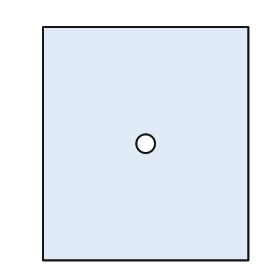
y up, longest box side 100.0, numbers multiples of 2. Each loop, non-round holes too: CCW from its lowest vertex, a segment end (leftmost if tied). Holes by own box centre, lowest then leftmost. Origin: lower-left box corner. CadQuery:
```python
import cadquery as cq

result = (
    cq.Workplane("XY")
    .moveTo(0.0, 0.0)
    .lineTo(88.0, 0.0)
    .lineTo(88.0, 100.0)
    .lineTo(0.0, 100.0)
    .close()
    .moveTo(44.0, 50.0)
    .circle(4.0)
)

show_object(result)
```